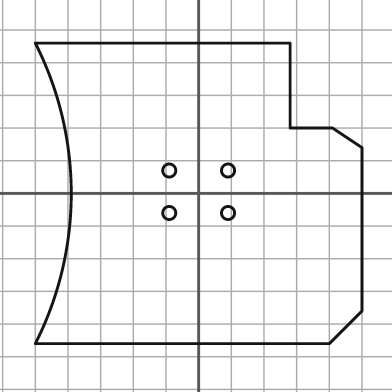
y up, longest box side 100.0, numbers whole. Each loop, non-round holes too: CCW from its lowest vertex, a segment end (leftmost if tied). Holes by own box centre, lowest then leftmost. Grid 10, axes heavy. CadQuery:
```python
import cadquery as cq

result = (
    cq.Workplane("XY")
    .moveTo(-50.0, -46.0)
    .lineTo(40.0, -46.0)
    .lineTo(50.0, -36.0)
    .lineTo(50.0, 14.0)
    .lineTo(41.0, 20.0)
    .lineTo(28.0, 20.0)
    .lineTo(28.0, 46.0)
    .lineTo(-50.0, 46.0)
    .threePointArc((-39.0, 0.0), (-50.0, -46.0))
    .close()
    .moveTo(-9.0, -6.0)
    .circle(2.0)
    .moveTo(9.0, -6.0)
    .circle(2.0)
    .moveTo(-9.0, 7.0)
    .circle(2.0)
    .moveTo(9.0, 7.0)
    .circle(2.0)
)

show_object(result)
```